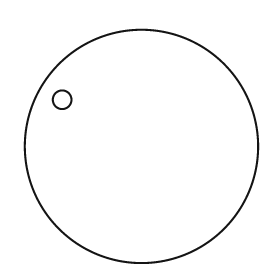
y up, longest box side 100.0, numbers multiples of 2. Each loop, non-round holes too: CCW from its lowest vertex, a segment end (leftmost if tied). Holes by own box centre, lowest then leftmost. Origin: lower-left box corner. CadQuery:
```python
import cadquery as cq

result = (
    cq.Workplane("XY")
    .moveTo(50.0, 50.0)
    .circle(50.0)
    .moveTo(16.0, 70.0)
    .circle(4.0)
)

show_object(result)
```